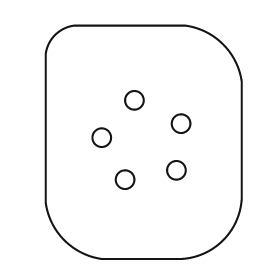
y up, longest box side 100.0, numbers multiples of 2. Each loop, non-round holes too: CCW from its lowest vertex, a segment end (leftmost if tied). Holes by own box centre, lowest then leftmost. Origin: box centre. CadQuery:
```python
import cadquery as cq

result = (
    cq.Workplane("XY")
    .moveTo(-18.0, -50.0)
    .lineTo(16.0, -50.0)
    .threePointArc((34.0, -42.0), (42.0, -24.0))
    .lineTo(42.0, 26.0)
    .threePointArc((34.0, 42.0), (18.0, 50.0))
    .lineTo(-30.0, 50.0)
    .threePointArc((-38.0, 46.0), (-42.0, 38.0))
    .lineTo(-42.0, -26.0)
    .threePointArc((-34.0, -42.0), (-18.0, -50.0))
    .close()
    .moveTo(-8.0, -16.0)
    .circle(4.0)
    .moveTo(14.0, -12.0)
    .circle(4.0)
    .moveTo(-18.0, 2.0)
    .circle(4.0)
    .moveTo(16.0, 8.0)
    .circle(4.0)
    .moveTo(-4.0, 18.0)
    .circle(4.0)
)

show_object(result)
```